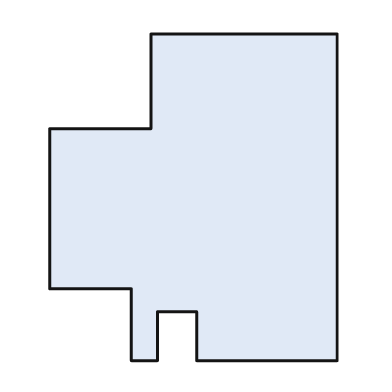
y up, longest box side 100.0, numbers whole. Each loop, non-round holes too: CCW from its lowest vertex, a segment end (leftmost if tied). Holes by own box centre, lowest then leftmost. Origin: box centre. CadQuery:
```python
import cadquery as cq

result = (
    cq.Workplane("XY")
    .moveTo(-19.0, -50.0)
    .lineTo(-11.0, -50.0)
    .lineTo(-11.0, -35.0)
    .lineTo(1.0, -35.0)
    .lineTo(1.0, -50.0)
    .lineTo(44.0, -50.0)
    .lineTo(44.0, 50.0)
    .lineTo(-13.0, 50.0)
    .lineTo(-13.0, 21.0)
    .lineTo(-44.0, 21.0)
    .lineTo(-44.0, -28.0)
    .lineTo(-19.0, -28.0)
    .close()
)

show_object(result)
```